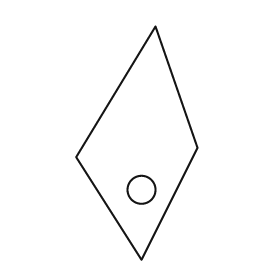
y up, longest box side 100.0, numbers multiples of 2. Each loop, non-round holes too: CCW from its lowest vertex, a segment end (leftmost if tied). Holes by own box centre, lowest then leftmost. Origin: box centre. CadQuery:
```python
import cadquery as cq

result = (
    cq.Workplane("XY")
    .moveTo(2.0, -50.0)
    .lineTo(26.0, -2.0)
    .lineTo(8.0, 50.0)
    .lineTo(-26.0, -6.0)
    .close()
    .moveTo(2.0, -20.0)
    .circle(6.0)
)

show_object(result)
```